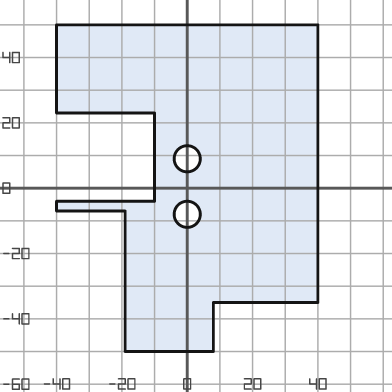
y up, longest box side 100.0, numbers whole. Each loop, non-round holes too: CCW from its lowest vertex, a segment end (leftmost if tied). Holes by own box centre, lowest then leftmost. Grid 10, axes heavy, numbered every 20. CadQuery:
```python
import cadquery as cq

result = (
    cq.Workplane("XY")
    .moveTo(-19.0, -50.0)
    .lineTo(8.0, -50.0)
    .lineTo(8.0, -35.0)
    .lineTo(40.0, -35.0)
    .lineTo(40.0, 50.0)
    .lineTo(-40.0, 50.0)
    .lineTo(-40.0, 23.0)
    .lineTo(-10.0, 23.0)
    .lineTo(-10.0, -4.0)
    .lineTo(-40.0, -4.0)
    .lineTo(-40.0, -7.0)
    .lineTo(-19.0, -7.0)
    .close()
    .moveTo(0.0, -8.0)
    .circle(4.0)
    .moveTo(0.0, 9.0)
    .circle(4.0)
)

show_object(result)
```